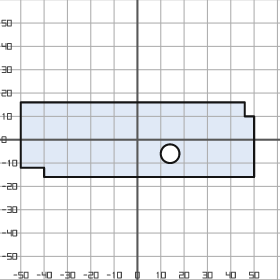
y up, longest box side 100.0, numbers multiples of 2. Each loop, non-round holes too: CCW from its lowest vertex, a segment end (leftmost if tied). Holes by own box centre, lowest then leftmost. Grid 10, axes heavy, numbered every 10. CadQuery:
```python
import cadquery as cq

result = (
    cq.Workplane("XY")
    .moveTo(-40.0, -16.0)
    .lineTo(50.0, -16.0)
    .lineTo(50.0, 10.0)
    .lineTo(46.0, 10.0)
    .lineTo(46.0, 16.0)
    .lineTo(-50.0, 16.0)
    .lineTo(-50.0, -12.0)
    .lineTo(-40.0, -12.0)
    .close()
    .moveTo(14.0, -6.0)
    .circle(4.0)
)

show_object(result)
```